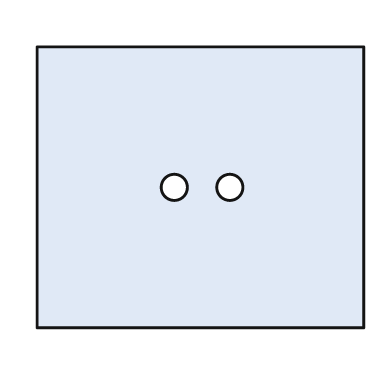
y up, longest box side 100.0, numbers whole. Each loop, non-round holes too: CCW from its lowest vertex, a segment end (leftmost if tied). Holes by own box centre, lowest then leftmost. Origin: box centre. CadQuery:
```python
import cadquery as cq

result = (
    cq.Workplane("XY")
    .moveTo(-50.0, -43.0)
    .lineTo(50.0, -43.0)
    .lineTo(50.0, 43.0)
    .lineTo(-50.0, 43.0)
    .close()
    .moveTo(-8.0, 0.0)
    .circle(4.0)
    .moveTo(9.0, 0.0)
    .circle(4.0)
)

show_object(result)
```